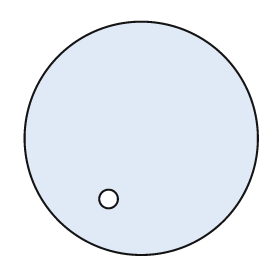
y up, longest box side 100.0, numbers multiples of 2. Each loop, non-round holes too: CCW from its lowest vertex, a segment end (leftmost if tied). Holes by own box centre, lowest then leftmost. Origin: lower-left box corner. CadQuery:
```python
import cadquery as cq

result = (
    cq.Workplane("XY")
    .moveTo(50.0, 50.0)
    .circle(50.0)
    .moveTo(36.0, 24.0)
    .circle(4.0)
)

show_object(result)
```